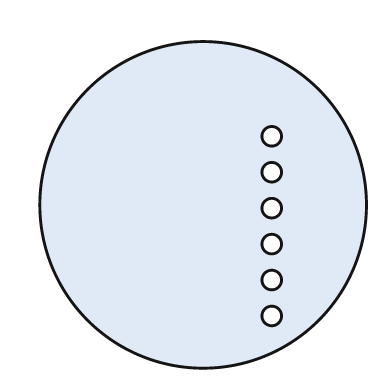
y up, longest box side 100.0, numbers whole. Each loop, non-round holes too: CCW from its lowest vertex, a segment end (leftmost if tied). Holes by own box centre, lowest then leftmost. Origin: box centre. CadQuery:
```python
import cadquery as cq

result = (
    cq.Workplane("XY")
    .moveTo(0.0, 0.0)
    .circle(50.0)
    .moveTo(21.0, -34.0)
    .circle(3.0)
    .moveTo(21.0, -23.0)
    .circle(3.0)
    .moveTo(21.0, -12.0)
    .circle(3.0)
    .moveTo(21.0, -1.0)
    .circle(3.0)
    .moveTo(21.0, 10.0)
    .circle(3.0)
    .moveTo(21.0, 21.0)
    .circle(3.0)
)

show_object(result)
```